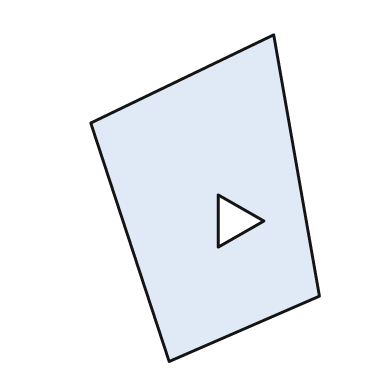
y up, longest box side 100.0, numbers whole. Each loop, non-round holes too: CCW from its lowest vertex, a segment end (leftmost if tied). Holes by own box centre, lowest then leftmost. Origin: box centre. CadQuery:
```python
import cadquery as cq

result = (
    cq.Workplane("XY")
    .moveTo(-11.0, -50.0)
    .lineTo(35.0, -30.0)
    .lineTo(21.0, 50.0)
    .lineTo(-35.0, 23.0)
    .close()
    .moveTo(4.0, -15.0)
    .lineTo(18.0, -7.0)
    .lineTo(4.0, 1.0)
    .close()
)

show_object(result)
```